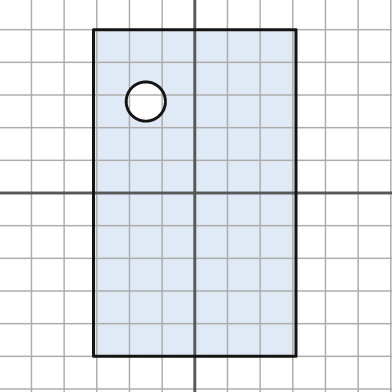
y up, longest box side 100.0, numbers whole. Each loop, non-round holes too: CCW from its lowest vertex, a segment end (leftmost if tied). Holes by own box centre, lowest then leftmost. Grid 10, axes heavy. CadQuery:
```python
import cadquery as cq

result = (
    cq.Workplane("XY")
    .moveTo(-31.0, -50.0)
    .lineTo(31.0, -50.0)
    .lineTo(31.0, 50.0)
    .lineTo(-31.0, 50.0)
    .close()
    .moveTo(-15.0, 28.0)
    .circle(6.0)
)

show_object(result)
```